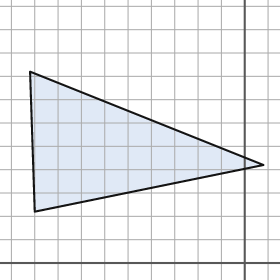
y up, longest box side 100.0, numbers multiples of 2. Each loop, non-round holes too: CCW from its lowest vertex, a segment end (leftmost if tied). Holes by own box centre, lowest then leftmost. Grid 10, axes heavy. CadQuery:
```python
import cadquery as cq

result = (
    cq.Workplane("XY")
    .moveTo(-90.0, 22.0)
    .lineTo(8.0, 42.0)
    .lineTo(-92.0, 82.0)
    .close()
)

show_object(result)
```